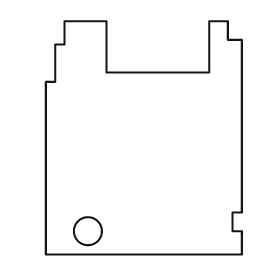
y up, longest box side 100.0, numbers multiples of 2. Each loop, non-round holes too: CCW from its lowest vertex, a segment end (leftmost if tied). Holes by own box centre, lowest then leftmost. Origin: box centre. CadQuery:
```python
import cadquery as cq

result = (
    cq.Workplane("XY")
    .moveTo(-42.0, -50.0)
    .lineTo(42.0, -50.0)
    .lineTo(42.0, -40.0)
    .lineTo(38.0, -40.0)
    .lineTo(38.0, -32.0)
    .lineTo(42.0, -32.0)
    .lineTo(42.0, 42.0)
    .lineTo(36.0, 42.0)
    .lineTo(36.0, 50.0)
    .lineTo(28.0, 50.0)
    .lineTo(28.0, 28.0)
    .lineTo(-16.0, 28.0)
    .lineTo(-16.0, 50.0)
    .lineTo(-34.0, 50.0)
    .lineTo(-34.0, 40.0)
    .lineTo(-38.0, 40.0)
    .lineTo(-38.0, 24.0)
    .lineTo(-42.0, 24.0)
    .close()
    .moveTo(-24.0, -40.0)
    .circle(6.0)
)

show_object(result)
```